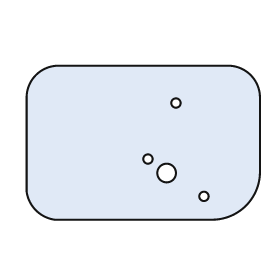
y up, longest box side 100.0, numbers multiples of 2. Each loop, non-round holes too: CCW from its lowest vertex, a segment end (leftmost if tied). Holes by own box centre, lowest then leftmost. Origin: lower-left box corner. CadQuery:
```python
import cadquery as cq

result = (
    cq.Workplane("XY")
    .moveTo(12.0, 0.0)
    .lineTo(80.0, 0.0)
    .threePointArc((94.0, 6.0), (100.0, 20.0))
    .lineTo(100.0, 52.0)
    .threePointArc((96.0, 62.0), (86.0, 66.0))
    .lineTo(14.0, 66.0)
    .threePointArc((4.0, 62.0), (0.0, 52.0))
    .lineTo(0.0, 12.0)
    .threePointArc((4.0, 4.0), (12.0, 0.0))
    .close()
    .moveTo(76.0, 10.0)
    .circle(2.0)
    .moveTo(60.0, 20.0)
    .circle(4.0)
    .moveTo(52.0, 26.0)
    .circle(2.0)
    .moveTo(64.0, 50.0)
    .circle(2.0)
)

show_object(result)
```